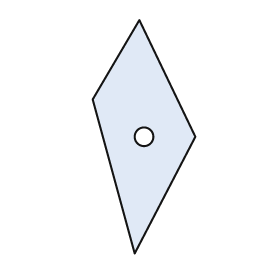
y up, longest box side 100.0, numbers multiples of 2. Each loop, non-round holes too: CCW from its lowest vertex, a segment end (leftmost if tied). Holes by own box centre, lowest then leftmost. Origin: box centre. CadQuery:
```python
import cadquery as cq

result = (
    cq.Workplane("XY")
    .moveTo(-4.0, -50.0)
    .lineTo(22.0, 0.0)
    .lineTo(-2.0, 50.0)
    .lineTo(-22.0, 16.0)
    .close()
    .moveTo(0.0, 0.0)
    .circle(4.0)
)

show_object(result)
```